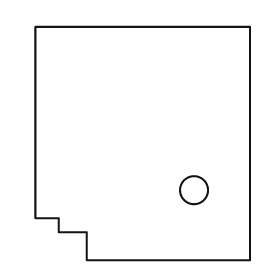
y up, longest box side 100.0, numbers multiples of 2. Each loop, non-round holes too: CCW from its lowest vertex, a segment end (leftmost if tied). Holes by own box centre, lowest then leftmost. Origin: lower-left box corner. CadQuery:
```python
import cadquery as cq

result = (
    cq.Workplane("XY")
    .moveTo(22.0, 0.0)
    .lineTo(92.0, 0.0)
    .lineTo(92.0, 100.0)
    .lineTo(0.0, 100.0)
    .lineTo(0.0, 18.0)
    .lineTo(10.0, 18.0)
    .lineTo(10.0, 12.0)
    .lineTo(22.0, 12.0)
    .close()
    .moveTo(68.0, 30.0)
    .circle(6.0)
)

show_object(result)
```